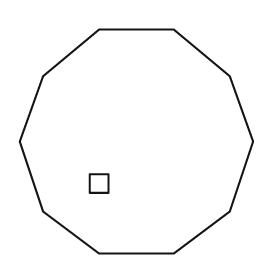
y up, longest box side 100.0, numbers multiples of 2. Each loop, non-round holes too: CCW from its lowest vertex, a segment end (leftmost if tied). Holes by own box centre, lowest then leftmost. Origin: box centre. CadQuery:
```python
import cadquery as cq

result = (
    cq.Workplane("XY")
    .moveTo(-16.0, -48.0)
    .lineTo(16.0, -48.0)
    .lineTo(40.0, -30.0)
    .lineTo(50.0, 0.0)
    .lineTo(40.0, 28.0)
    .lineTo(16.0, 48.0)
    .lineTo(-16.0, 48.0)
    .lineTo(-40.0, 28.0)
    .lineTo(-50.0, 0.0)
    .lineTo(-40.0, -30.0)
    .close()
    .moveTo(-20.0, -22.0)
    .lineTo(-12.0, -22.0)
    .lineTo(-12.0, -14.0)
    .lineTo(-20.0, -14.0)
    .close()
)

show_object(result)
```